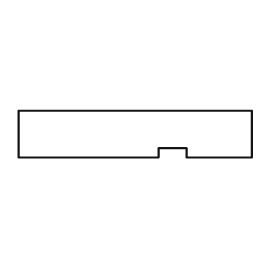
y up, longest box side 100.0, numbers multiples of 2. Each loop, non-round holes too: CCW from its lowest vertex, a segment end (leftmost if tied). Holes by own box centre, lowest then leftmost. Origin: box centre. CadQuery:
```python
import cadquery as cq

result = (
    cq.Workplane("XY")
    .moveTo(-50.0, -10.0)
    .lineTo(10.0, -10.0)
    .lineTo(10.0, -6.0)
    .lineTo(22.0, -6.0)
    .lineTo(22.0, -10.0)
    .lineTo(50.0, -10.0)
    .lineTo(50.0, 10.0)
    .lineTo(-50.0, 10.0)
    .close()
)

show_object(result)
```